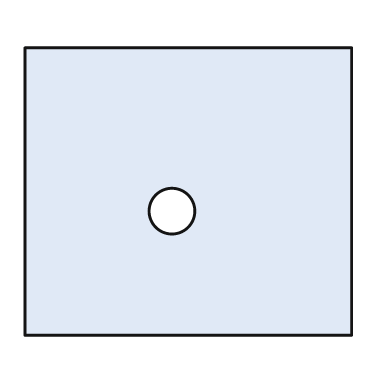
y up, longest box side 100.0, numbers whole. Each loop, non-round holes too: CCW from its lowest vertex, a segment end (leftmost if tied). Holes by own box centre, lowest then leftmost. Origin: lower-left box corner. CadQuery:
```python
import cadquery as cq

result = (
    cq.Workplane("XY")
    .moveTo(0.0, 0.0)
    .lineTo(100.0, 0.0)
    .lineTo(100.0, 88.0)
    .lineTo(0.0, 88.0)
    .close()
    .moveTo(45.0, 38.0)
    .circle(7.0)
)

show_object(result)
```